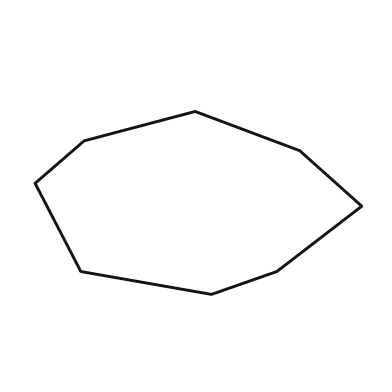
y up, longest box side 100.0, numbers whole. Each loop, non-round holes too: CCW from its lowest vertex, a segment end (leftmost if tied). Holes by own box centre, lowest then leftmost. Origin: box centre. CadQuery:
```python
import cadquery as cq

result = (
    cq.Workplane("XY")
    .moveTo(4.0, -28.0)
    .lineTo(24.0, -21.0)
    .lineTo(50.0, -1.0)
    .lineTo(31.0, 16.0)
    .lineTo(-1.0, 28.0)
    .lineTo(-35.0, 19.0)
    .lineTo(-50.0, 6.0)
    .lineTo(-36.0, -21.0)
    .close()
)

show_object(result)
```